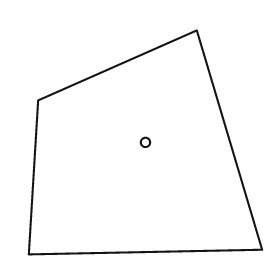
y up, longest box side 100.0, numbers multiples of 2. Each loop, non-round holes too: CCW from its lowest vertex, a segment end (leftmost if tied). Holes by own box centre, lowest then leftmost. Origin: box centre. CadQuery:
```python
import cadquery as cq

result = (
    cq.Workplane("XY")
    .moveTo(-50.0, -48.0)
    .lineTo(50.0, -46.0)
    .lineTo(22.0, 48.0)
    .lineTo(-46.0, 18.0)
    .close()
    .moveTo(0.0, 0.0)
    .circle(2.0)
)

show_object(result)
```